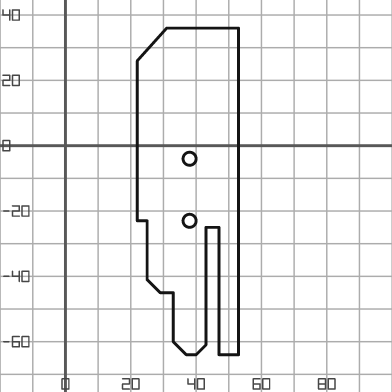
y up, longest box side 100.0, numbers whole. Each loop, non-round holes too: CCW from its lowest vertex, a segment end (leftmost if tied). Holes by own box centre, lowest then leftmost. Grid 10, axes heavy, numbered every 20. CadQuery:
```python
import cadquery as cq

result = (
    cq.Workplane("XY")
    .moveTo(37.0, -64.0)
    .lineTo(40.0, -64.0)
    .lineTo(43.0, -61.0)
    .lineTo(43.0, -25.0)
    .lineTo(47.0, -25.0)
    .lineTo(47.0, -64.0)
    .lineTo(53.0, -64.0)
    .lineTo(53.0, 36.0)
    .lineTo(31.0, 36.0)
    .lineTo(22.0, 26.0)
    .lineTo(22.0, -23.0)
    .lineTo(25.0, -23.0)
    .lineTo(25.0, -41.0)
    .lineTo(29.0, -45.0)
    .lineTo(33.0, -45.0)
    .lineTo(33.0, -60.0)
    .close()
    .moveTo(38.0, -23.0)
    .circle(2.0)
    .moveTo(38.0, -4.0)
    .circle(2.0)
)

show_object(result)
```